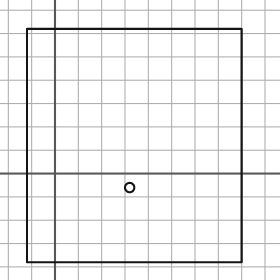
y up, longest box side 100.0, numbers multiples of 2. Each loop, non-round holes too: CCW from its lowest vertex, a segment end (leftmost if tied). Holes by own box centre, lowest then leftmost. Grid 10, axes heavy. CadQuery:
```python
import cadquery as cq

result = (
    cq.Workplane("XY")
    .moveTo(-12.0, -38.0)
    .lineTo(80.0, -38.0)
    .lineTo(80.0, 62.0)
    .lineTo(-12.0, 62.0)
    .close()
    .moveTo(32.0, -6.0)
    .circle(2.0)
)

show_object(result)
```